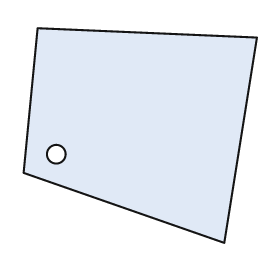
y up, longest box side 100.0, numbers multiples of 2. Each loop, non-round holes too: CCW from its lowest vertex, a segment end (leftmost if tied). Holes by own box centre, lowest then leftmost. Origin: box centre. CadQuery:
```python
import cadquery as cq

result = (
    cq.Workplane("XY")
    .moveTo(36.0, -46.0)
    .lineTo(50.0, 42.0)
    .lineTo(-44.0, 46.0)
    .lineTo(-50.0, -16.0)
    .close()
    .moveTo(-36.0, -8.0)
    .circle(4.0)
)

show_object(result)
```